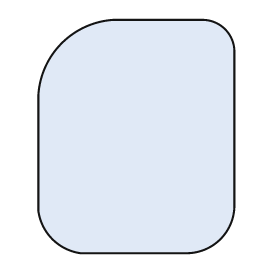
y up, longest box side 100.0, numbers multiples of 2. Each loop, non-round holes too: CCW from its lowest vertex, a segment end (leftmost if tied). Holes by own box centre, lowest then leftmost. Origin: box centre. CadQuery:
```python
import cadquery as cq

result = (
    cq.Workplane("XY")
    .moveTo(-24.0, -50.0)
    .lineTo(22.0, -50.0)
    .threePointArc((36.0, -44.0), (42.0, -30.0))
    .lineTo(42.0, 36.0)
    .threePointArc((38.0, 46.0), (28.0, 50.0))
    .lineTo(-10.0, 50.0)
    .threePointArc((-32.0, 40.0), (-42.0, 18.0))
    .lineTo(-42.0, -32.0)
    .threePointArc((-36.0, -44.0), (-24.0, -50.0))
    .close()
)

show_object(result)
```